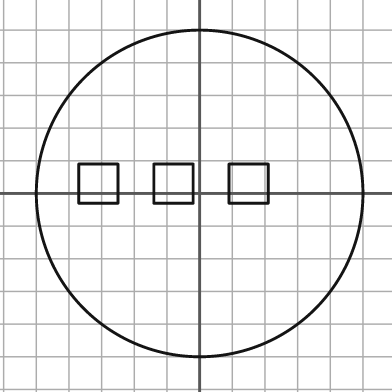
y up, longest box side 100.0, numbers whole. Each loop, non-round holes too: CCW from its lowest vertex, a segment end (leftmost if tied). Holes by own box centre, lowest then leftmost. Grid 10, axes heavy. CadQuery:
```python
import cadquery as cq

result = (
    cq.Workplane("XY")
    .moveTo(0.0, 0.0)
    .circle(50.0)
    .moveTo(-37.0, -3.0)
    .lineTo(-25.0, -3.0)
    .lineTo(-25.0, 9.0)
    .lineTo(-37.0, 9.0)
    .close()
    .moveTo(-14.0, -3.0)
    .lineTo(-2.0, -3.0)
    .lineTo(-2.0, 9.0)
    .lineTo(-14.0, 9.0)
    .close()
    .moveTo(9.0, -3.0)
    .lineTo(21.0, -3.0)
    .lineTo(21.0, 9.0)
    .lineTo(9.0, 9.0)
    .close()
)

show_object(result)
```